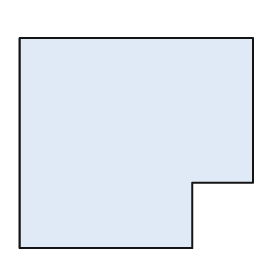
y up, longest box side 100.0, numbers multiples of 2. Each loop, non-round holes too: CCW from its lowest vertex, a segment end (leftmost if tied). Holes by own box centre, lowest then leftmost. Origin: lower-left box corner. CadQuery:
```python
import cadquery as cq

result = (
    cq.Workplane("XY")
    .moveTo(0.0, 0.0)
    .lineTo(74.0, 0.0)
    .lineTo(74.0, 28.0)
    .lineTo(100.0, 28.0)
    .lineTo(100.0, 90.0)
    .lineTo(0.0, 90.0)
    .close()
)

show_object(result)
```